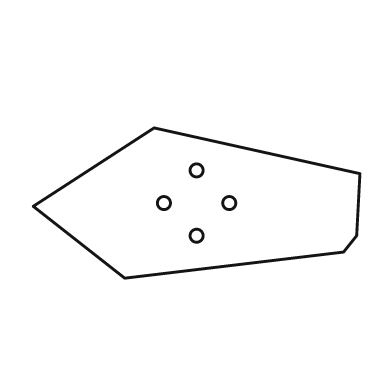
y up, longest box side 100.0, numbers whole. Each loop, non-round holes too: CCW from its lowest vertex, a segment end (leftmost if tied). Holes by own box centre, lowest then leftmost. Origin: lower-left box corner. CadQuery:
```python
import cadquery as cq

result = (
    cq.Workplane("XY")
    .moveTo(28.0, 0.0)
    .lineTo(95.0, 8.0)
    .lineTo(99.0, 13.0)
    .lineTo(100.0, 32.0)
    .lineTo(37.0, 46.0)
    .lineTo(0.0, 22.0)
    .close()
    .moveTo(50.0, 13.0)
    .circle(2.0)
    .moveTo(40.0, 23.0)
    .circle(2.0)
    .moveTo(60.0, 23.0)
    .circle(2.0)
    .moveTo(50.0, 33.0)
    .circle(2.0)
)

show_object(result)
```